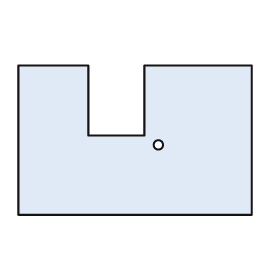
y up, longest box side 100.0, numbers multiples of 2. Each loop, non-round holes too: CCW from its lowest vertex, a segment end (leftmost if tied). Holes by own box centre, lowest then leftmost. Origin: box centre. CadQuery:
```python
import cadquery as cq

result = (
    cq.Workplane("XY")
    .moveTo(-50.0, -32.0)
    .lineTo(50.0, -32.0)
    .lineTo(50.0, 32.0)
    .lineTo(4.0, 32.0)
    .lineTo(4.0, 2.0)
    .lineTo(-20.0, 2.0)
    .lineTo(-20.0, 32.0)
    .lineTo(-50.0, 32.0)
    .close()
    .moveTo(10.0, -2.0)
    .circle(2.0)
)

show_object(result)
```